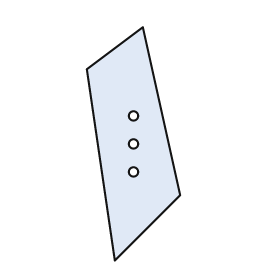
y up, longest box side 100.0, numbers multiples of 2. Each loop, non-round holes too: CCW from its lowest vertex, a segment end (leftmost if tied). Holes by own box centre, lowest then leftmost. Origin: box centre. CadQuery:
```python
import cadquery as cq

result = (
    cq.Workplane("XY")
    .moveTo(-8.0, -50.0)
    .lineTo(20.0, -22.0)
    .lineTo(4.0, 50.0)
    .lineTo(-20.0, 32.0)
    .close()
    .moveTo(0.0, -12.0)
    .circle(2.0)
    .moveTo(0.0, 0.0)
    .circle(2.0)
    .moveTo(0.0, 12.0)
    .circle(2.0)
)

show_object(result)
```